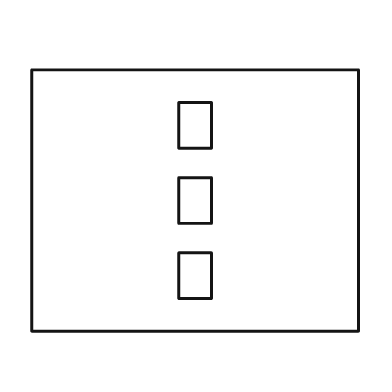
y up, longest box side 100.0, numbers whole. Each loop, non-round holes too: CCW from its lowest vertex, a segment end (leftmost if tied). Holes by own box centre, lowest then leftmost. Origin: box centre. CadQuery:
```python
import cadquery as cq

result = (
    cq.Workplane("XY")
    .moveTo(-50.0, -40.0)
    .lineTo(50.0, -40.0)
    .lineTo(50.0, 40.0)
    .lineTo(-50.0, 40.0)
    .close()
    .moveTo(-5.0, -30.0)
    .lineTo(5.0, -30.0)
    .lineTo(5.0, -16.0)
    .lineTo(-5.0, -16.0)
    .close()
    .moveTo(-5.0, -7.0)
    .lineTo(5.0, -7.0)
    .lineTo(5.0, 7.0)
    .lineTo(-5.0, 7.0)
    .close()
    .moveTo(-5.0, 16.0)
    .lineTo(5.0, 16.0)
    .lineTo(5.0, 30.0)
    .lineTo(-5.0, 30.0)
    .close()
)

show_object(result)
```